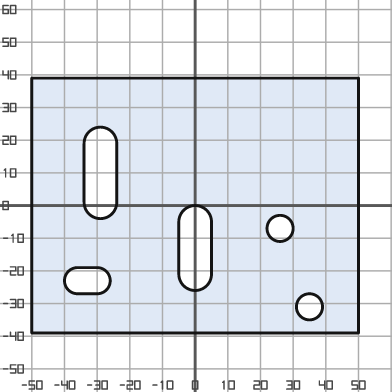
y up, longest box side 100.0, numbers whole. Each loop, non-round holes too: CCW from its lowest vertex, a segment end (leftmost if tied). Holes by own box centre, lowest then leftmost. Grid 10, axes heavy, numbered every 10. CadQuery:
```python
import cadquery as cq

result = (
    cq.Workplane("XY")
    .moveTo(-50.0, -39.0)
    .lineTo(50.0, -39.0)
    .lineTo(50.0, 39.0)
    .lineTo(-50.0, 39.0)
    .close()
    .moveTo(35.0, -31.0)
    .circle(4.0)
    .moveTo(-36.0, -27.0)
    .lineTo(-30.0, -27.0)
    .threePointArc((-26.0, -23.0), (-30.0, -19.0))
    .lineTo(-36.0, -19.0)
    .threePointArc((-40.0, -23.0), (-36.0, -27.0))
    .close()
    .moveTo(-5.0, -21.0)
    .threePointArc((0.0, -26.0), (5.0, -21.0))
    .lineTo(5.0, -5.0)
    .threePointArc((0.0, 0.0), (-5.0, -5.0))
    .close()
    .moveTo(26.0, -7.0)
    .circle(4.0)
    .moveTo(-34.0, 1.0)
    .threePointArc((-29.0, -4.0), (-24.0, 1.0))
    .lineTo(-24.0, 19.0)
    .threePointArc((-29.0, 24.0), (-34.0, 19.0))
    .close()
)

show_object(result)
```